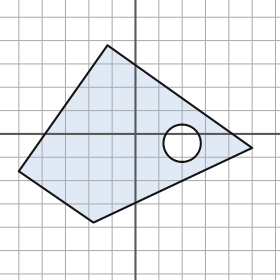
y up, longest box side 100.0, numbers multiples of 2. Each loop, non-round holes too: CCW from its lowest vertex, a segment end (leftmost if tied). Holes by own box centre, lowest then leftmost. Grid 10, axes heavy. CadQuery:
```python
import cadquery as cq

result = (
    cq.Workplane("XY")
    .moveTo(-18.0, -38.0)
    .lineTo(50.0, -6.0)
    .lineTo(-12.0, 38.0)
    .lineTo(-50.0, -16.0)
    .close()
    .moveTo(20.0, -4.0)
    .circle(8.0)
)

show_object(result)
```